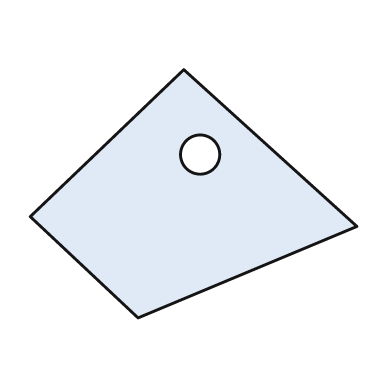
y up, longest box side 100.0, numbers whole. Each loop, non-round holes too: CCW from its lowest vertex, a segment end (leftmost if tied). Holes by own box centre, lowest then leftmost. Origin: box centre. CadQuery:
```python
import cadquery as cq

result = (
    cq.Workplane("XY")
    .moveTo(-17.0, -38.0)
    .lineTo(50.0, -10.0)
    .lineTo(-3.0, 38.0)
    .lineTo(-50.0, -7.0)
    .close()
    .moveTo(2.0, 12.0)
    .circle(6.0)
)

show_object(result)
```